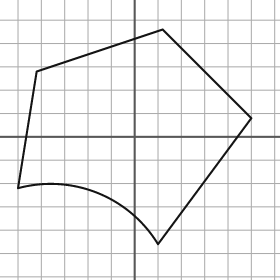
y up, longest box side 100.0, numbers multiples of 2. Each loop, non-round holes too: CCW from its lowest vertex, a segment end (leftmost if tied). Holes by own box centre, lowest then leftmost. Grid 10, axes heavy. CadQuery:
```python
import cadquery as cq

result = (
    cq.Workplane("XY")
    .moveTo(10.0, -46.0)
    .lineTo(50.0, 8.0)
    .lineTo(12.0, 46.0)
    .lineTo(-42.0, 28.0)
    .lineTo(-50.0, -22.0)
    .threePointArc((-16.0, -24.0), (10.0, -46.0))
    .close()
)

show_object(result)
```